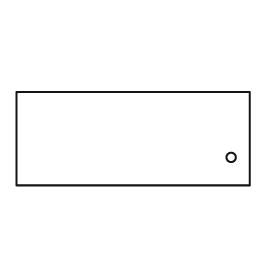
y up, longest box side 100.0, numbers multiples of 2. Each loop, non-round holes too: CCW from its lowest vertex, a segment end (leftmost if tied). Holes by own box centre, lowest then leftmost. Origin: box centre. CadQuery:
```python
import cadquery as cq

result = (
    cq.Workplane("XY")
    .moveTo(-50.0, -20.0)
    .lineTo(50.0, -20.0)
    .lineTo(50.0, 20.0)
    .lineTo(-50.0, 20.0)
    .close()
    .moveTo(42.0, -8.0)
    .circle(2.0)
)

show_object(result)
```